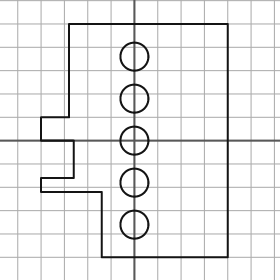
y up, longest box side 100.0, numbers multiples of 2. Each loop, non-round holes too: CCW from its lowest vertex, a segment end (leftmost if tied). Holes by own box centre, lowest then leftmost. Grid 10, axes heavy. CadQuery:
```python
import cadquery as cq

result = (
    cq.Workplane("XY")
    .moveTo(-14.0, -50.0)
    .lineTo(40.0, -50.0)
    .lineTo(40.0, 50.0)
    .lineTo(-28.0, 50.0)
    .lineTo(-28.0, 10.0)
    .lineTo(-40.0, 10.0)
    .lineTo(-40.0, 0.0)
    .lineTo(-26.0, 0.0)
    .lineTo(-26.0, -16.0)
    .lineTo(-40.0, -16.0)
    .lineTo(-40.0, -22.0)
    .lineTo(-14.0, -22.0)
    .close()
    .moveTo(0.0, -36.0)
    .circle(6.0)
    .moveTo(0.0, -18.0)
    .circle(6.0)
    .moveTo(0.0, 0.0)
    .circle(6.0)
    .moveTo(0.0, 18.0)
    .circle(6.0)
    .moveTo(0.0, 36.0)
    .circle(6.0)
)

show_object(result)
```